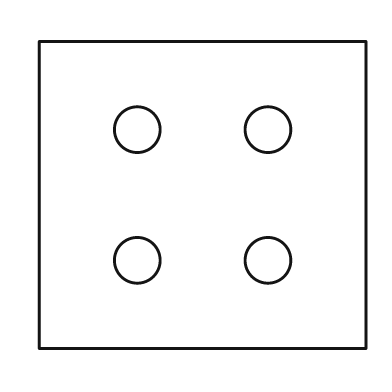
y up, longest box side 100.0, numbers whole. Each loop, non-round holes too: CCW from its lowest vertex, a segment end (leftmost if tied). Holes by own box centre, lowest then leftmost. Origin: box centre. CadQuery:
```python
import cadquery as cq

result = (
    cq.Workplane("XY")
    .moveTo(-50.0, -47.0)
    .lineTo(50.0, -47.0)
    .lineTo(50.0, 47.0)
    .lineTo(-50.0, 47.0)
    .close()
    .moveTo(-20.0, -20.0)
    .circle(7.0)
    .moveTo(20.0, -20.0)
    .circle(7.0)
    .moveTo(-20.0, 20.0)
    .circle(7.0)
    .moveTo(20.0, 20.0)
    .circle(7.0)
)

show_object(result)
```